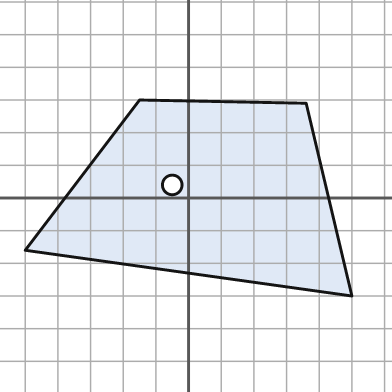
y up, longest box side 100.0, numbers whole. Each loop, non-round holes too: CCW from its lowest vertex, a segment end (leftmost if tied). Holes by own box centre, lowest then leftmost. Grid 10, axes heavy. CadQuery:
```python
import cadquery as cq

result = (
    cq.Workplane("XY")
    .moveTo(50.0, -30.0)
    .lineTo(36.0, 29.0)
    .lineTo(-15.0, 30.0)
    .lineTo(-50.0, -16.0)
    .close()
    .moveTo(-5.0, 4.0)
    .circle(3.0)
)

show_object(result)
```